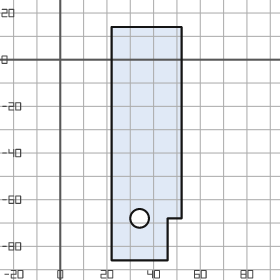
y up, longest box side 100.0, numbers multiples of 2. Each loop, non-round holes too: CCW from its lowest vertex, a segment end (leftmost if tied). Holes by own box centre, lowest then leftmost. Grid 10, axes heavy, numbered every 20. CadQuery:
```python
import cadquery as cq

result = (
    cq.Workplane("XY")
    .moveTo(22.0, -86.0)
    .lineTo(46.0, -86.0)
    .lineTo(46.0, -68.0)
    .lineTo(52.0, -68.0)
    .lineTo(52.0, 14.0)
    .lineTo(22.0, 14.0)
    .close()
    .moveTo(34.0, -68.0)
    .circle(4.0)
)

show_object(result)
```